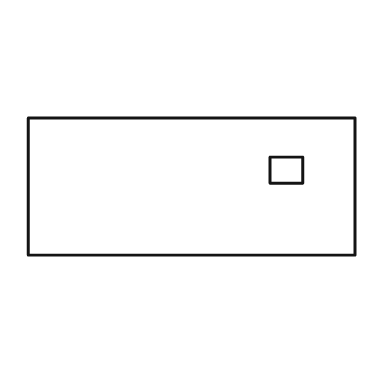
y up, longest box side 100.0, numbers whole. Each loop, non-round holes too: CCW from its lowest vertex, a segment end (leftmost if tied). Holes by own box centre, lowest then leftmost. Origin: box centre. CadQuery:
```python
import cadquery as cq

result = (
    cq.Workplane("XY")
    .moveTo(-50.0, -21.0)
    .lineTo(50.0, -21.0)
    .lineTo(50.0, 21.0)
    .lineTo(-50.0, 21.0)
    .close()
    .moveTo(24.0, 1.0)
    .lineTo(34.0, 1.0)
    .lineTo(34.0, 9.0)
    .lineTo(24.0, 9.0)
    .close()
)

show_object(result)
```